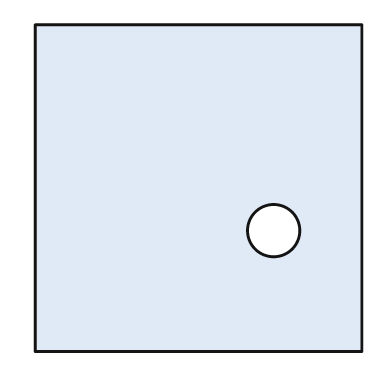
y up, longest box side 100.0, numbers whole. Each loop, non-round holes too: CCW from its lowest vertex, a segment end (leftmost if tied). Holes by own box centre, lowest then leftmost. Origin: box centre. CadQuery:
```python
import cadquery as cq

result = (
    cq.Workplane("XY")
    .moveTo(-50.0, -50.0)
    .lineTo(50.0, -50.0)
    .lineTo(50.0, 50.0)
    .lineTo(-50.0, 50.0)
    .close()
    .moveTo(23.0, -13.0)
    .circle(8.0)
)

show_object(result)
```